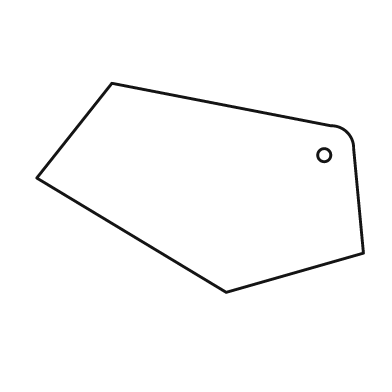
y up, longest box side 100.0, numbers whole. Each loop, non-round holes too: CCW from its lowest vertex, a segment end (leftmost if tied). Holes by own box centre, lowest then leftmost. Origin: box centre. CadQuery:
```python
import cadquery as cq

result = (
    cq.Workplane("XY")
    .moveTo(8.0, -32.0)
    .lineTo(50.0, -20.0)
    .lineTo(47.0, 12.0)
    .threePointArc((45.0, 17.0), (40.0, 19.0))
    .lineTo(-27.0, 32.0)
    .lineTo(-50.0, 3.0)
    .close()
    .moveTo(38.0, 10.0)
    .circle(2.0)
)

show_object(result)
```